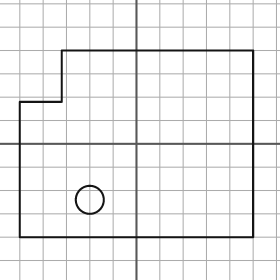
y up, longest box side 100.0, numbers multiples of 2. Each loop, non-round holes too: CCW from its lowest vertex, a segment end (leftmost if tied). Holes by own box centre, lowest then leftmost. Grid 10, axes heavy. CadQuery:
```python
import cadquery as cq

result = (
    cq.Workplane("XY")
    .moveTo(-50.0, -40.0)
    .lineTo(50.0, -40.0)
    .lineTo(50.0, 40.0)
    .lineTo(-32.0, 40.0)
    .lineTo(-32.0, 18.0)
    .lineTo(-50.0, 18.0)
    .close()
    .moveTo(-20.0, -24.0)
    .circle(6.0)
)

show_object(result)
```